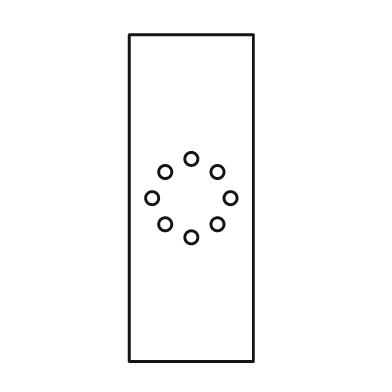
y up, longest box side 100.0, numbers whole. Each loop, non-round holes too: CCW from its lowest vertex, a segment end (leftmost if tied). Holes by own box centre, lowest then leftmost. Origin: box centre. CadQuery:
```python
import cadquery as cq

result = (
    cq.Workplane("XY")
    .moveTo(-19.0, -50.0)
    .lineTo(19.0, -50.0)
    .lineTo(19.0, 50.0)
    .lineTo(-19.0, 50.0)
    .close()
    .moveTo(0.0, -12.0)
    .circle(2.0)
    .moveTo(-8.0, -8.0)
    .circle(2.0)
    .moveTo(8.0, -8.0)
    .circle(2.0)
    .moveTo(-12.0, 0.0)
    .circle(2.0)
    .moveTo(12.0, 0.0)
    .circle(2.0)
    .moveTo(-8.0, 8.0)
    .circle(2.0)
    .moveTo(8.0, 8.0)
    .circle(2.0)
    .moveTo(0.0, 12.0)
    .circle(2.0)
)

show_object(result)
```